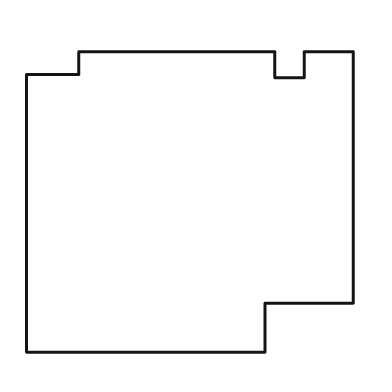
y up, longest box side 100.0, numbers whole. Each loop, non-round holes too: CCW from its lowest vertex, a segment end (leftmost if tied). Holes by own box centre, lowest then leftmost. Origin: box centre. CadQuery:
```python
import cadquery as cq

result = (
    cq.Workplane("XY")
    .moveTo(-50.0, -46.0)
    .lineTo(23.0, -46.0)
    .lineTo(23.0, -31.0)
    .lineTo(50.0, -31.0)
    .lineTo(50.0, 46.0)
    .lineTo(35.0, 46.0)
    .lineTo(35.0, 38.0)
    .lineTo(26.0, 38.0)
    .lineTo(26.0, 46.0)
    .lineTo(-34.0, 46.0)
    .lineTo(-34.0, 39.0)
    .lineTo(-50.0, 39.0)
    .close()
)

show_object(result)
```